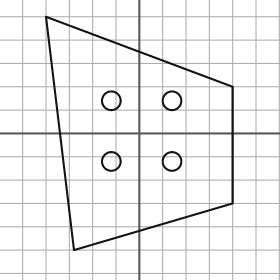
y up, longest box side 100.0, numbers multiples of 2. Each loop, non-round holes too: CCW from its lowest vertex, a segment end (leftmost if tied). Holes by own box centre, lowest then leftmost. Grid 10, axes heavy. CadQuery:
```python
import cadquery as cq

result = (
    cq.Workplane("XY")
    .moveTo(-28.0, -50.0)
    .lineTo(40.0, -30.0)
    .lineTo(40.0, 20.0)
    .lineTo(-40.0, 50.0)
    .close()
    .moveTo(-12.0, -12.0)
    .circle(4.0)
    .moveTo(14.0, -12.0)
    .circle(4.0)
    .moveTo(-12.0, 14.0)
    .circle(4.0)
    .moveTo(14.0, 14.0)
    .circle(4.0)
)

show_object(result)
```